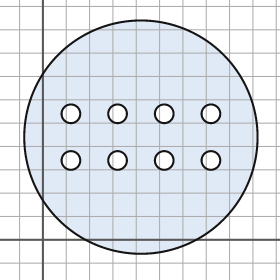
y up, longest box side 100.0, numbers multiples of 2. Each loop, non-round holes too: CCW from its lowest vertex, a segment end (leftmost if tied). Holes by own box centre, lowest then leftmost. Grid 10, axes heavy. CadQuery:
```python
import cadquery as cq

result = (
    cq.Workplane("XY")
    .moveTo(42.0, 44.0)
    .circle(50.0)
    .moveTo(12.0, 34.0)
    .circle(4.0)
    .moveTo(32.0, 34.0)
    .circle(4.0)
    .moveTo(52.0, 34.0)
    .circle(4.0)
    .moveTo(72.0, 34.0)
    .circle(4.0)
    .moveTo(12.0, 54.0)
    .circle(4.0)
    .moveTo(32.0, 54.0)
    .circle(4.0)
    .moveTo(52.0, 54.0)
    .circle(4.0)
    .moveTo(72.0, 54.0)
    .circle(4.0)
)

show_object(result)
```